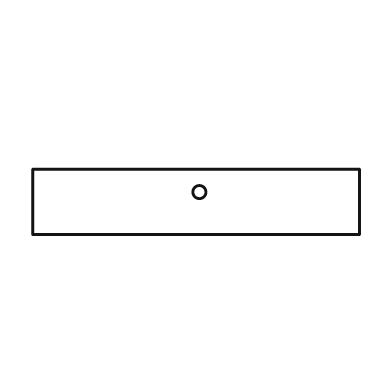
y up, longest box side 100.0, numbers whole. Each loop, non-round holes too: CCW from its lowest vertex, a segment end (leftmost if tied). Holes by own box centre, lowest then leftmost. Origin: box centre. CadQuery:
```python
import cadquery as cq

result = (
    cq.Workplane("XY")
    .moveTo(-50.0, -10.0)
    .lineTo(50.0, -10.0)
    .lineTo(50.0, 10.0)
    .lineTo(-50.0, 10.0)
    .close()
    .moveTo(1.0, 3.0)
    .circle(2.0)
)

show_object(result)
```